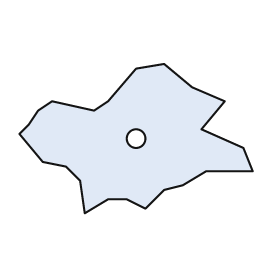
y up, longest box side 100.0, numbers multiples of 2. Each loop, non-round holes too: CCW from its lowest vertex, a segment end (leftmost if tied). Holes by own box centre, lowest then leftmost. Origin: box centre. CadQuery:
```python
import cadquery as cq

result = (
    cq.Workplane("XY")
    .moveTo(-22.0, -32.0)
    .lineTo(-12.0, -26.0)
    .lineTo(-4.0, -26.0)
    .lineTo(4.0, -30.0)
    .lineTo(12.0, -22.0)
    .lineTo(20.0, -20.0)
    .lineTo(30.0, -14.0)
    .lineTo(50.0, -14.0)
    .lineTo(46.0, -4.0)
    .lineTo(28.0, 4.0)
    .lineTo(38.0, 16.0)
    .lineTo(24.0, 22.0)
    .lineTo(12.0, 32.0)
    .lineTo(0.0, 30.0)
    .lineTo(-12.0, 16.0)
    .lineTo(-18.0, 12.0)
    .lineTo(-36.0, 16.0)
    .lineTo(-42.0, 12.0)
    .lineTo(-46.0, 6.0)
    .lineTo(-50.0, 2.0)
    .lineTo(-40.0, -10.0)
    .lineTo(-30.0, -12.0)
    .lineTo(-24.0, -18.0)
    .close()
    .moveTo(0.0, 0.0)
    .circle(4.0)
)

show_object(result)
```